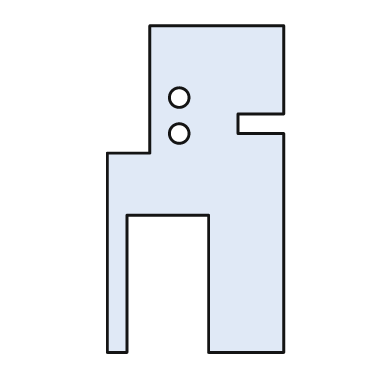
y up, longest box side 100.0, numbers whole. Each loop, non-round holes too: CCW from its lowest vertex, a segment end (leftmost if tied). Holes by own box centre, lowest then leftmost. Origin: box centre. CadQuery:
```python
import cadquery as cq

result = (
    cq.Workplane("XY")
    .moveTo(-27.0, -50.0)
    .lineTo(-21.0, -50.0)
    .lineTo(-21.0, -8.0)
    .lineTo(4.0, -8.0)
    .lineTo(4.0, -50.0)
    .lineTo(27.0, -50.0)
    .lineTo(27.0, 17.0)
    .lineTo(13.0, 17.0)
    .lineTo(13.0, 23.0)
    .lineTo(27.0, 23.0)
    .lineTo(27.0, 50.0)
    .lineTo(-14.0, 50.0)
    .lineTo(-14.0, 11.0)
    .lineTo(-27.0, 11.0)
    .close()
    .moveTo(-5.0, 17.0)
    .circle(3.0)
    .moveTo(-5.0, 28.0)
    .circle(3.0)
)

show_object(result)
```